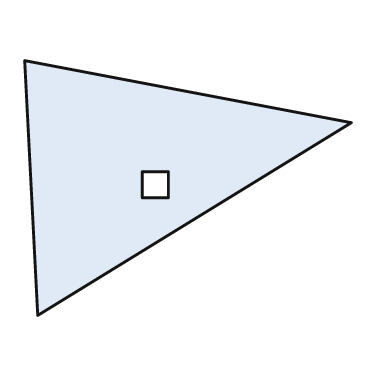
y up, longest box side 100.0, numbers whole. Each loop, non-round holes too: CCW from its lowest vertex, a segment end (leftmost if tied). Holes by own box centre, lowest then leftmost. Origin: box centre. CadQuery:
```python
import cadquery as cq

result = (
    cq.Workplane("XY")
    .moveTo(-46.0, -39.0)
    .lineTo(50.0, 20.0)
    .lineTo(-50.0, 39.0)
    .close()
    .moveTo(-14.0, -3.0)
    .lineTo(-6.0, -3.0)
    .lineTo(-6.0, 5.0)
    .lineTo(-14.0, 5.0)
    .close()
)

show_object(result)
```